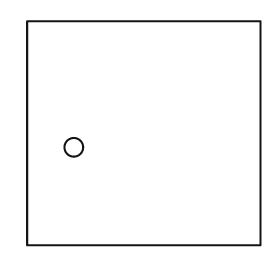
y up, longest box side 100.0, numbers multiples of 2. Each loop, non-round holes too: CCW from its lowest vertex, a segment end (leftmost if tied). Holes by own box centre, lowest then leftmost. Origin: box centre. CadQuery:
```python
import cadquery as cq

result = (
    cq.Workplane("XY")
    .moveTo(-50.0, -48.0)
    .lineTo(50.0, -48.0)
    .lineTo(50.0, 48.0)
    .lineTo(-50.0, 48.0)
    .close()
    .moveTo(-30.0, -6.0)
    .circle(4.0)
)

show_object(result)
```